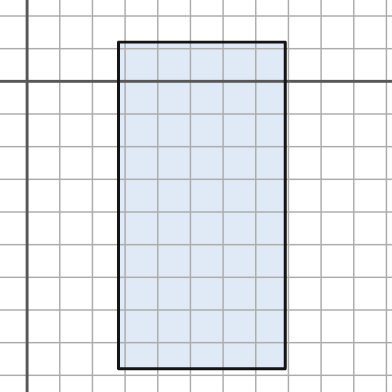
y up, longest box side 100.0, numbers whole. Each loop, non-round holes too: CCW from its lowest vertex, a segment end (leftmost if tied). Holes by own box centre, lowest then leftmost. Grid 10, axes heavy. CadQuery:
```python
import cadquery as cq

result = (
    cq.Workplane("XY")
    .moveTo(28.0, -88.0)
    .lineTo(79.0, -88.0)
    .lineTo(79.0, 12.0)
    .lineTo(28.0, 12.0)
    .close()
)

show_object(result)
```